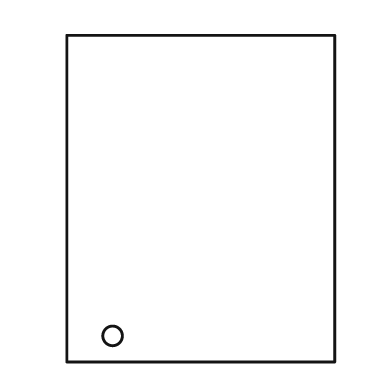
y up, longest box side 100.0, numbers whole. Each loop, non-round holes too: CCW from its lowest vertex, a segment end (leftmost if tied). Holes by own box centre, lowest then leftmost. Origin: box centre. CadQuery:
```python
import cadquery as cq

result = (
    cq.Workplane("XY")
    .moveTo(-41.0, -50.0)
    .lineTo(41.0, -50.0)
    .lineTo(41.0, 50.0)
    .lineTo(-41.0, 50.0)
    .close()
    .moveTo(-27.0, -42.0)
    .circle(3.0)
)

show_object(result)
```